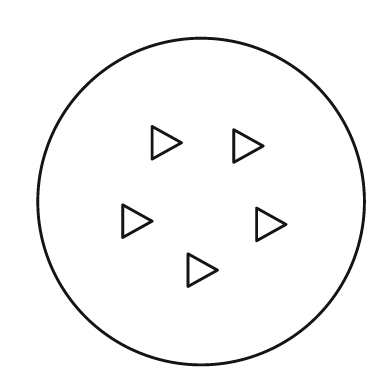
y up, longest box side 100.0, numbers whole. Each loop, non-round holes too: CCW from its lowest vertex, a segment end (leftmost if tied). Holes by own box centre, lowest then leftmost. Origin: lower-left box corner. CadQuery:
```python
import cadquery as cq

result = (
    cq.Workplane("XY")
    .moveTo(50.0, 50.0)
    .circle(50.0)
    .moveTo(46.0, 24.0)
    .lineTo(55.0, 29.0)
    .lineTo(46.0, 34.0)
    .close()
    .moveTo(67.0, 38.0)
    .lineTo(76.0, 43.0)
    .lineTo(67.0, 48.0)
    .close()
    .moveTo(26.0, 39.0)
    .lineTo(35.0, 44.0)
    .lineTo(26.0, 49.0)
    .close()
    .moveTo(60.0, 62.0)
    .lineTo(69.0, 67.0)
    .lineTo(60.0, 72.0)
    .close()
    .moveTo(35.0, 63.0)
    .lineTo(44.0, 68.0)
    .lineTo(35.0, 73.0)
    .close()
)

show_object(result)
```